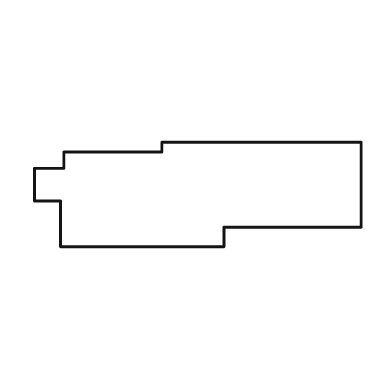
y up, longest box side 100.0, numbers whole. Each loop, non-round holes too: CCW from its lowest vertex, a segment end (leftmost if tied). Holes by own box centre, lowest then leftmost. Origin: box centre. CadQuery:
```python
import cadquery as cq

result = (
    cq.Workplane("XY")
    .moveTo(-42.0, -16.0)
    .lineTo(8.0, -16.0)
    .lineTo(8.0, -10.0)
    .lineTo(50.0, -10.0)
    .lineTo(50.0, 16.0)
    .lineTo(-11.0, 16.0)
    .lineTo(-11.0, 13.0)
    .lineTo(-41.0, 13.0)
    .lineTo(-41.0, 8.0)
    .lineTo(-50.0, 8.0)
    .lineTo(-50.0, -2.0)
    .lineTo(-42.0, -2.0)
    .close()
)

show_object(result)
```